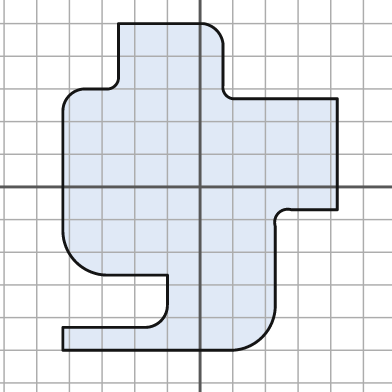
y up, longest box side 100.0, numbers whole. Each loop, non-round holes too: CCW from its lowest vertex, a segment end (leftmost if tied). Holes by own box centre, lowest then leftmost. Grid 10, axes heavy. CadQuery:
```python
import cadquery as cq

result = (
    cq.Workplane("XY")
    .moveTo(-42.0, -50.0)
    .lineTo(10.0, -50.0)
    .threePointArc((19.0, -46.0), (23.0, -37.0))
    .lineTo(23.0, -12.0)
    .threePointArc((24.0, -8.0), (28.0, -7.0))
    .lineTo(42.0, -7.0)
    .lineTo(42.0, 27.0)
    .lineTo(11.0, 27.0)
    .threePointArc((8.0, 28.0), (7.0, 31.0))
    .lineTo(7.0, 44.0)
    .threePointArc((5.0, 48.0), (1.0, 50.0))
    .lineTo(-25.0, 50.0)
    .lineTo(-25.0, 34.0)
    .threePointArc((-26.0, 31.0), (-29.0, 30.0))
    .lineTo(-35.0, 30.0)
    .threePointArc((-40.0, 28.0), (-42.0, 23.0))
    .lineTo(-42.0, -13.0)
    .threePointArc((-38.0, -23.0), (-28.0, -27.0))
    .lineTo(-10.0, -27.0)
    .lineTo(-10.0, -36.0)
    .threePointArc((-12.0, -41.0), (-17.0, -43.0))
    .lineTo(-42.0, -43.0)
    .close()
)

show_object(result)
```